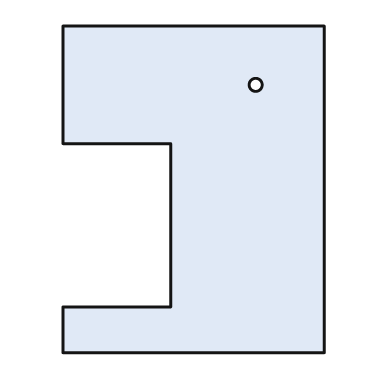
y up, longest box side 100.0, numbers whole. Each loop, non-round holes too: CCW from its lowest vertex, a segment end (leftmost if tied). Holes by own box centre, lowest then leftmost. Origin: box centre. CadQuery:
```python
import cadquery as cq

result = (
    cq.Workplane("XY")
    .moveTo(-40.0, -50.0)
    .lineTo(40.0, -50.0)
    .lineTo(40.0, 50.0)
    .lineTo(-40.0, 50.0)
    .lineTo(-40.0, 14.0)
    .lineTo(-7.0, 14.0)
    .lineTo(-7.0, -36.0)
    .lineTo(-40.0, -36.0)
    .close()
    .moveTo(19.0, 32.0)
    .circle(2.0)
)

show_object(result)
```